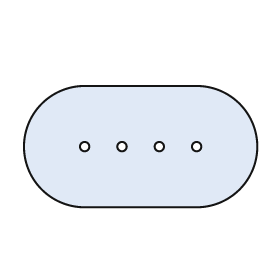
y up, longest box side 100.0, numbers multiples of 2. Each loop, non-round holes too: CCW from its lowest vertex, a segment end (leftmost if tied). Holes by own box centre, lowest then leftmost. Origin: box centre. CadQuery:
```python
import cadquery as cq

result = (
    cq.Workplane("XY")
    .moveTo(-24.0, -26.0)
    .lineTo(24.0, -26.0)
    .threePointArc((50.0, 0.0), (24.0, 26.0))
    .lineTo(-24.0, 26.0)
    .threePointArc((-50.0, 0.0), (-24.0, -26.0))
    .close()
    .moveTo(-24.0, 0.0)
    .circle(2.0)
    .moveTo(-8.0, 0.0)
    .circle(2.0)
    .moveTo(8.0, 0.0)
    .circle(2.0)
    .moveTo(24.0, 0.0)
    .circle(2.0)
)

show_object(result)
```